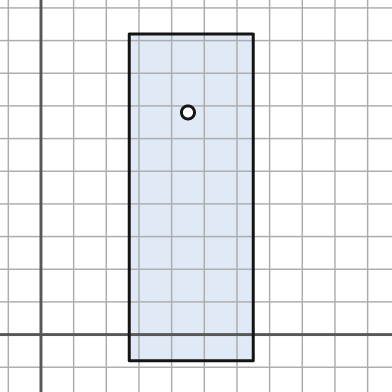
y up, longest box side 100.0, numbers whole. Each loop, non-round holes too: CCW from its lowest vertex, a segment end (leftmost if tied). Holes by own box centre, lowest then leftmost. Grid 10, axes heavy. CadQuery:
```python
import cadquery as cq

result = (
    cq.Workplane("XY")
    .moveTo(27.0, -8.0)
    .lineTo(65.0, -8.0)
    .lineTo(65.0, 92.0)
    .lineTo(27.0, 92.0)
    .close()
    .moveTo(45.0, 68.0)
    .circle(2.0)
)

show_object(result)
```